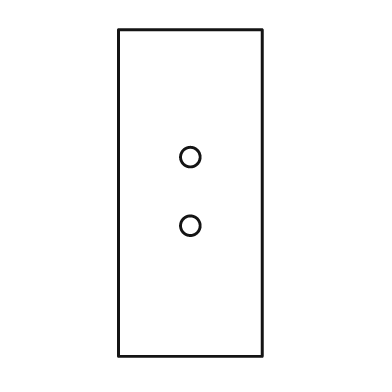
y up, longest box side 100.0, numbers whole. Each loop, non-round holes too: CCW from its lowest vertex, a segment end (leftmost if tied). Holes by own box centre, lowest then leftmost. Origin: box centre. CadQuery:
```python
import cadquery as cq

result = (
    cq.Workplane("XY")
    .moveTo(-22.0, -50.0)
    .lineTo(22.0, -50.0)
    .lineTo(22.0, 50.0)
    .lineTo(-22.0, 50.0)
    .close()
    .moveTo(0.0, -10.0)
    .circle(3.0)
    .moveTo(0.0, 11.0)
    .circle(3.0)
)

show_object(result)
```